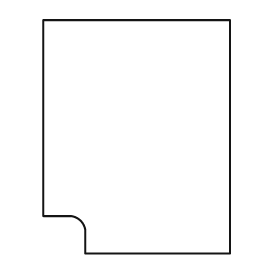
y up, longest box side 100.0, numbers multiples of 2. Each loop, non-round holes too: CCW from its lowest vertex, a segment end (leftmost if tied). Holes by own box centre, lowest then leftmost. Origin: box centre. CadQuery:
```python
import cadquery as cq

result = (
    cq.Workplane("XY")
    .moveTo(-22.0, -50.0)
    .lineTo(40.0, -50.0)
    .lineTo(40.0, 50.0)
    .lineTo(-40.0, 50.0)
    .lineTo(-40.0, -34.0)
    .lineTo(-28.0, -34.0)
    .threePointArc((-24.0, -36.0), (-22.0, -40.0))
    .close()
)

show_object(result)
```